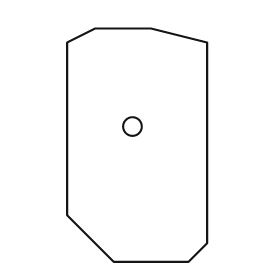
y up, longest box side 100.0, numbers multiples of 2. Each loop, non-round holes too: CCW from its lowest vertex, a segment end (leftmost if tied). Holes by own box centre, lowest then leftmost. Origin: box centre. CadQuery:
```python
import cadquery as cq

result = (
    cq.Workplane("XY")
    .moveTo(-10.0, -50.0)
    .lineTo(22.0, -50.0)
    .lineTo(30.0, -42.0)
    .lineTo(30.0, 44.0)
    .lineTo(6.0, 50.0)
    .lineTo(-18.0, 50.0)
    .lineTo(-30.0, 44.0)
    .lineTo(-30.0, -30.0)
    .close()
    .moveTo(-2.0, 8.0)
    .circle(4.0)
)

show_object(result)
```